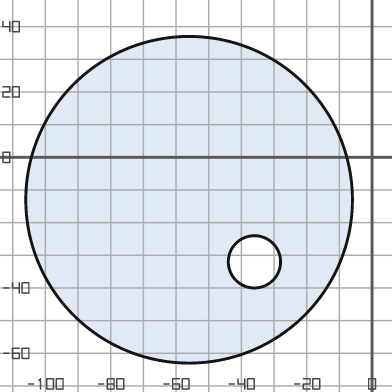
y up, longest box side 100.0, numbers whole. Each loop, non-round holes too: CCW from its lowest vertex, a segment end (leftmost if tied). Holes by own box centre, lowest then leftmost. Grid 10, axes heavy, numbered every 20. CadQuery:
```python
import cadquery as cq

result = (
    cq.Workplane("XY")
    .moveTo(-56.0, -13.0)
    .circle(50.0)
    .moveTo(-36.0, -32.0)
    .circle(8.0)
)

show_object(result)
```